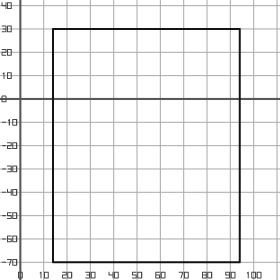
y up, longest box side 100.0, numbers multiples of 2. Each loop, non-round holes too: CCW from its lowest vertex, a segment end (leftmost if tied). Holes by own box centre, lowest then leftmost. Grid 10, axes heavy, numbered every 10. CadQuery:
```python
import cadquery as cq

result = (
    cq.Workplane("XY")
    .moveTo(14.0, -70.0)
    .lineTo(94.0, -70.0)
    .lineTo(94.0, 30.0)
    .lineTo(14.0, 30.0)
    .close()
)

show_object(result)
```